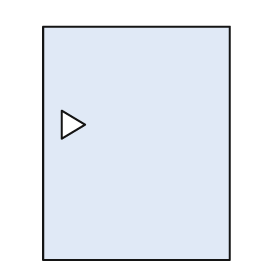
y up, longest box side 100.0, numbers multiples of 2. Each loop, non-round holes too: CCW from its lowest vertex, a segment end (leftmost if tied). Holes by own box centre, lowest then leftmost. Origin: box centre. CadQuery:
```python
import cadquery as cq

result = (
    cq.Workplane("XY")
    .moveTo(-40.0, -50.0)
    .lineTo(40.0, -50.0)
    .lineTo(40.0, 50.0)
    .lineTo(-40.0, 50.0)
    .close()
    .moveTo(-32.0, 2.0)
    .lineTo(-22.0, 8.0)
    .lineTo(-32.0, 14.0)
    .close()
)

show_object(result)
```